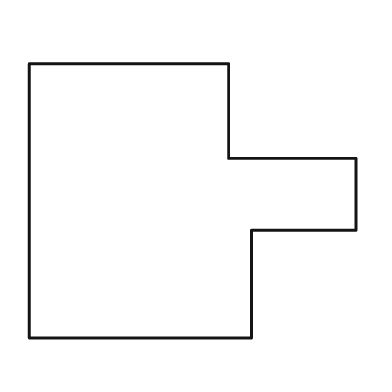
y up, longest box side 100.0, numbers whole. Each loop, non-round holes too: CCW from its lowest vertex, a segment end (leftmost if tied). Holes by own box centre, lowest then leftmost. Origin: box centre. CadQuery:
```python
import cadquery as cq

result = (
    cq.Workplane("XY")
    .moveTo(-50.0, -42.0)
    .lineTo(18.0, -42.0)
    .lineTo(18.0, -9.0)
    .lineTo(50.0, -9.0)
    .lineTo(50.0, 13.0)
    .lineTo(11.0, 13.0)
    .lineTo(11.0, 42.0)
    .lineTo(-50.0, 42.0)
    .close()
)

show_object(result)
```